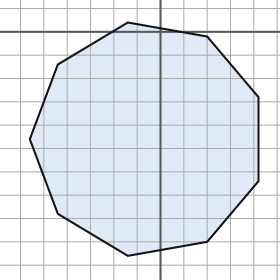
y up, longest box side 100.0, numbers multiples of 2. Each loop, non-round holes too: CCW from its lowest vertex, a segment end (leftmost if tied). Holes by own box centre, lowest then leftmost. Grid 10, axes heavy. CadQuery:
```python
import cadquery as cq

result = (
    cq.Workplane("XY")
    .moveTo(-14.0, -96.0)
    .lineTo(20.0, -90.0)
    .lineTo(42.0, -64.0)
    .lineTo(42.0, -28.0)
    .lineTo(20.0, -2.0)
    .lineTo(-14.0, 4.0)
    .lineTo(-44.0, -14.0)
    .lineTo(-56.0, -46.0)
    .lineTo(-44.0, -78.0)
    .close()
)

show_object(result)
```